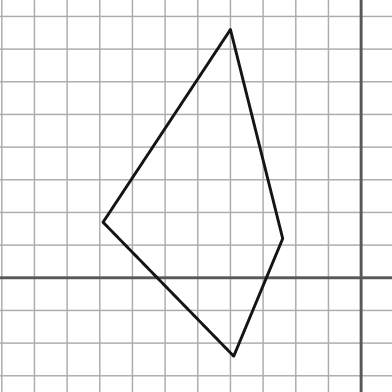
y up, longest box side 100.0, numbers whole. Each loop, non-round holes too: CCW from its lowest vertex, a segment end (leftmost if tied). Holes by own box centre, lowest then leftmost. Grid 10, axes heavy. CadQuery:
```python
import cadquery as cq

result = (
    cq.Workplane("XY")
    .moveTo(-39.0, -24.0)
    .lineTo(-24.0, 12.0)
    .lineTo(-40.0, 76.0)
    .lineTo(-79.0, 17.0)
    .close()
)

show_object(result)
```